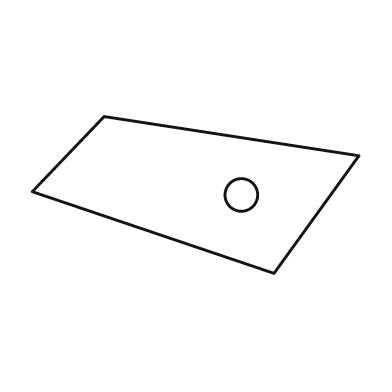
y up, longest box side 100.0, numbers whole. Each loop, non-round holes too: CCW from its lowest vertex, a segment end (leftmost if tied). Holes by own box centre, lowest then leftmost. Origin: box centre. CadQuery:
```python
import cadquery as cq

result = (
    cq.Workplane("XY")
    .moveTo(24.0, -24.0)
    .lineTo(50.0, 12.0)
    .lineTo(-28.0, 24.0)
    .lineTo(-50.0, 1.0)
    .close()
    .moveTo(14.0, 0.0)
    .circle(5.0)
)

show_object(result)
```